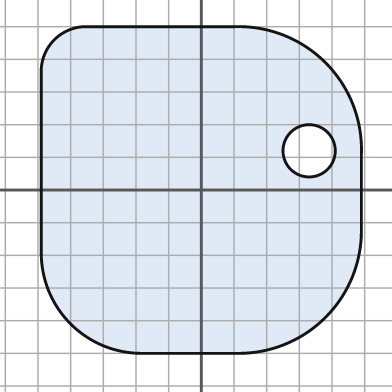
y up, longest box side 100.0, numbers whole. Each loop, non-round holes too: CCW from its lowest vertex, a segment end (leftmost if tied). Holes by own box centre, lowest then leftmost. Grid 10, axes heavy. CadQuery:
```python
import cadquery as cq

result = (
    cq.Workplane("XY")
    .moveTo(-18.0, -50.0)
    .lineTo(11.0, -50.0)
    .threePointArc((38.0, -39.0), (49.0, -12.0))
    .lineTo(49.0, 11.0)
    .threePointArc((38.0, 39.0), (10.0, 50.0))
    .lineTo(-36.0, 50.0)
    .threePointArc((-45.0, 46.0), (-49.0, 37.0))
    .lineTo(-49.0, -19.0)
    .threePointArc((-40.0, -41.0), (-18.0, -50.0))
    .close()
    .moveTo(33.0, 12.0)
    .circle(8.0)
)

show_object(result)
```